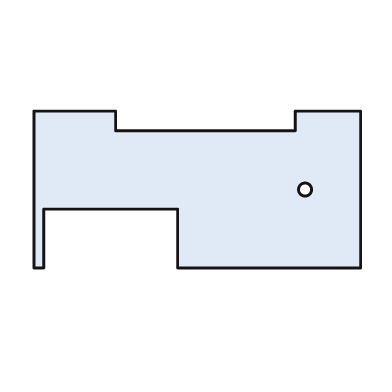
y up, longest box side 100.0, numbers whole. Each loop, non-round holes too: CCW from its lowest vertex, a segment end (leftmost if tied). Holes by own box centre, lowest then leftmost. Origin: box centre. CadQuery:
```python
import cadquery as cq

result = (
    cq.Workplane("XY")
    .moveTo(-50.0, -24.0)
    .lineTo(-47.0, -24.0)
    .lineTo(-47.0, -6.0)
    .lineTo(-6.0, -6.0)
    .lineTo(-6.0, -24.0)
    .lineTo(50.0, -24.0)
    .lineTo(50.0, 24.0)
    .lineTo(30.0, 24.0)
    .lineTo(30.0, 18.0)
    .lineTo(-25.0, 18.0)
    .lineTo(-25.0, 24.0)
    .lineTo(-50.0, 24.0)
    .close()
    .moveTo(33.0, 0.0)
    .circle(2.0)
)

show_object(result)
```